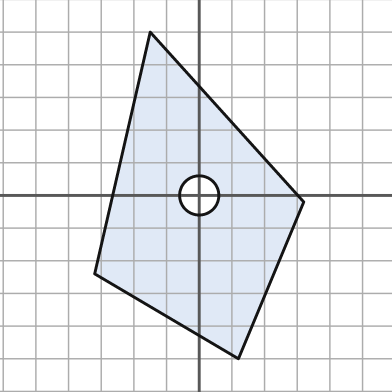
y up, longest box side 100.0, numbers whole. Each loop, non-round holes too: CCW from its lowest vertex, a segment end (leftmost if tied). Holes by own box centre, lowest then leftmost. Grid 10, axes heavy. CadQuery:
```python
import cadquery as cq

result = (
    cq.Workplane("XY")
    .moveTo(12.0, -50.0)
    .lineTo(32.0, -2.0)
    .lineTo(-15.0, 50.0)
    .lineTo(-32.0, -24.0)
    .close()
    .moveTo(0.0, 0.0)
    .circle(6.0)
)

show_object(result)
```